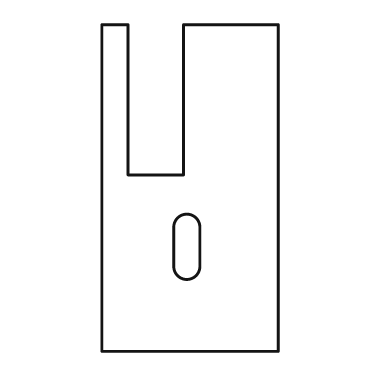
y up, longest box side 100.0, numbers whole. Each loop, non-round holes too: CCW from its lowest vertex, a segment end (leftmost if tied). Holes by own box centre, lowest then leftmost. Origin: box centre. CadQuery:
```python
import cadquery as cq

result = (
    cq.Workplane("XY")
    .moveTo(-27.0, -50.0)
    .lineTo(27.0, -50.0)
    .lineTo(27.0, 50.0)
    .lineTo(-2.0, 50.0)
    .lineTo(-2.0, 4.0)
    .lineTo(-19.0, 4.0)
    .lineTo(-19.0, 50.0)
    .lineTo(-27.0, 50.0)
    .close()
    .moveTo(-5.0, -24.0)
    .threePointArc((-1.0, -28.0), (3.0, -24.0))
    .lineTo(3.0, -12.0)
    .threePointArc((-1.0, -8.0), (-5.0, -12.0))
    .close()
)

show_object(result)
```